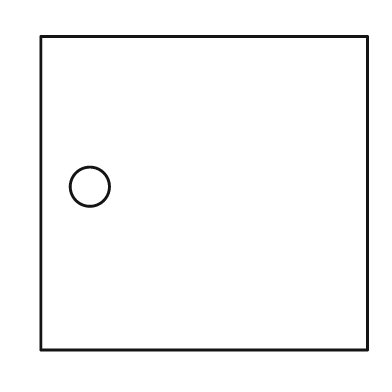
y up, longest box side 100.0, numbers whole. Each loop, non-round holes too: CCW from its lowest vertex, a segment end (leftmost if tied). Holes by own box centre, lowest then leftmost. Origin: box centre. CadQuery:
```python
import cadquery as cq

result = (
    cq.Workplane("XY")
    .moveTo(-50.0, -48.0)
    .lineTo(50.0, -48.0)
    .lineTo(50.0, 48.0)
    .lineTo(-50.0, 48.0)
    .close()
    .moveTo(-35.0, 2.0)
    .circle(6.0)
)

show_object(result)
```